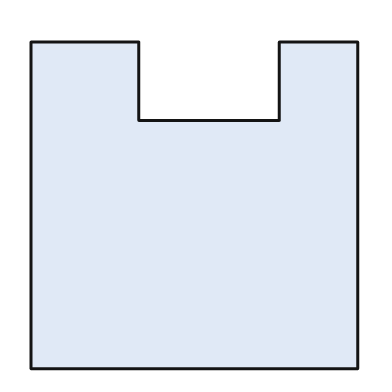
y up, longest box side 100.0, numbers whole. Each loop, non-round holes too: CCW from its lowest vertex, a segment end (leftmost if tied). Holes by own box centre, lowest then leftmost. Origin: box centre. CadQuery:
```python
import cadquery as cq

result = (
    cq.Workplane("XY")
    .moveTo(-50.0, -50.0)
    .lineTo(50.0, -50.0)
    .lineTo(50.0, 50.0)
    .lineTo(26.0, 50.0)
    .lineTo(26.0, 26.0)
    .lineTo(-17.0, 26.0)
    .lineTo(-17.0, 50.0)
    .lineTo(-50.0, 50.0)
    .close()
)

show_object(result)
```